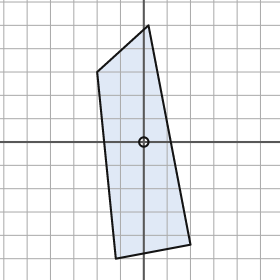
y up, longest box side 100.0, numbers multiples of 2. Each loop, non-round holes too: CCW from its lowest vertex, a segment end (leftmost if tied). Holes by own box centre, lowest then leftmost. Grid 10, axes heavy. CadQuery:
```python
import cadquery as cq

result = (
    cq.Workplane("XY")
    .moveTo(-12.0, -50.0)
    .lineTo(20.0, -44.0)
    .lineTo(2.0, 50.0)
    .lineTo(-20.0, 30.0)
    .close()
    .moveTo(0.0, 0.0)
    .circle(2.0)
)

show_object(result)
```